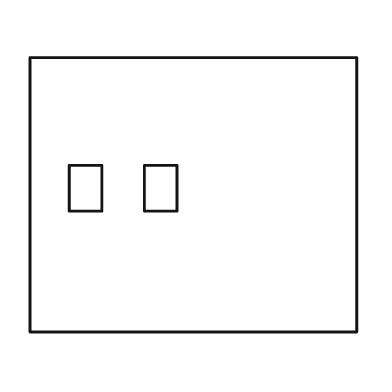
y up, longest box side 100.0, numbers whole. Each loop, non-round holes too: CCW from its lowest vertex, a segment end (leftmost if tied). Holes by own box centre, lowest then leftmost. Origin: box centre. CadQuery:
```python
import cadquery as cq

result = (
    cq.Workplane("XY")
    .moveTo(-50.0, -42.0)
    .lineTo(50.0, -42.0)
    .lineTo(50.0, 42.0)
    .lineTo(-50.0, 42.0)
    .close()
    .moveTo(-38.0, -5.0)
    .lineTo(-28.0, -5.0)
    .lineTo(-28.0, 9.0)
    .lineTo(-38.0, 9.0)
    .close()
    .moveTo(-15.0, -5.0)
    .lineTo(-5.0, -5.0)
    .lineTo(-5.0, 9.0)
    .lineTo(-15.0, 9.0)
    .close()
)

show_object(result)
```